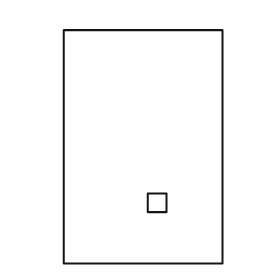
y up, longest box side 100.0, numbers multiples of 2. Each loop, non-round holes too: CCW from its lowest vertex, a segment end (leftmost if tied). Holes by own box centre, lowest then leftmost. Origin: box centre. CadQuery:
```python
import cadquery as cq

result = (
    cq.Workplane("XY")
    .moveTo(-34.0, -50.0)
    .lineTo(34.0, -50.0)
    .lineTo(34.0, 50.0)
    .lineTo(-34.0, 50.0)
    .close()
    .moveTo(2.0, -28.0)
    .lineTo(10.0, -28.0)
    .lineTo(10.0, -20.0)
    .lineTo(2.0, -20.0)
    .close()
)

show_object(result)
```